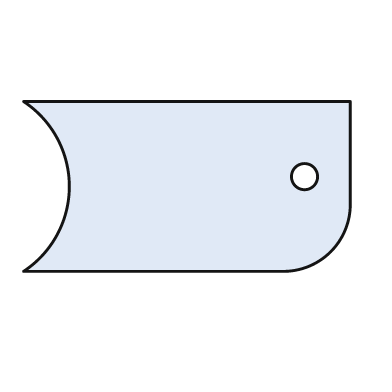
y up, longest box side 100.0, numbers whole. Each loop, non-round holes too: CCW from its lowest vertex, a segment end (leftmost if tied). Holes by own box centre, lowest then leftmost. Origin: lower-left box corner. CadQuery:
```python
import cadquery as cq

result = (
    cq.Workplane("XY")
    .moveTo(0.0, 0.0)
    .lineTo(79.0, 0.0)
    .threePointArc((94.0, 6.0), (100.0, 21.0))
    .lineTo(100.0, 52.0)
    .lineTo(0.0, 52.0)
    .threePointArc((14.0, 26.0), (0.0, 0.0))
    .close()
    .moveTo(86.0, 29.0)
    .circle(4.0)
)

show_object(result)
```